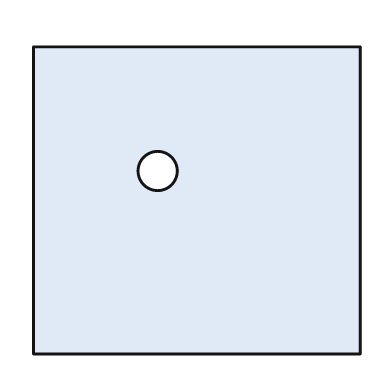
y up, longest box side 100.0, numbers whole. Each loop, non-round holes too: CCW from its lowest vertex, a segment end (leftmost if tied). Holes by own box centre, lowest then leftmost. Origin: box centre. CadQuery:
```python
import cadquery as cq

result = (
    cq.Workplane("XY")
    .moveTo(-50.0, -47.0)
    .lineTo(50.0, -47.0)
    .lineTo(50.0, 47.0)
    .lineTo(-50.0, 47.0)
    .close()
    .moveTo(-12.0, 9.0)
    .circle(6.0)
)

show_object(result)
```